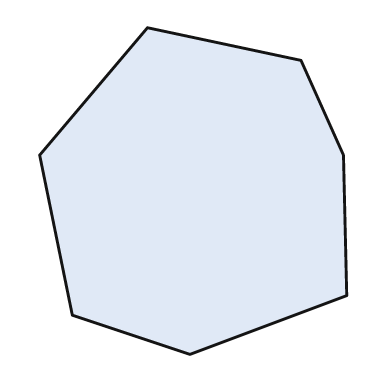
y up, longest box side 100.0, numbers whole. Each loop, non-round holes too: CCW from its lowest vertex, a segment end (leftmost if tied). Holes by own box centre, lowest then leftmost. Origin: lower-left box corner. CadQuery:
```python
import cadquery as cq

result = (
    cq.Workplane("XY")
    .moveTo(46.0, 0.0)
    .lineTo(94.0, 18.0)
    .lineTo(93.0, 61.0)
    .lineTo(80.0, 90.0)
    .lineTo(33.0, 100.0)
    .lineTo(0.0, 61.0)
    .lineTo(10.0, 12.0)
    .close()
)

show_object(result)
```